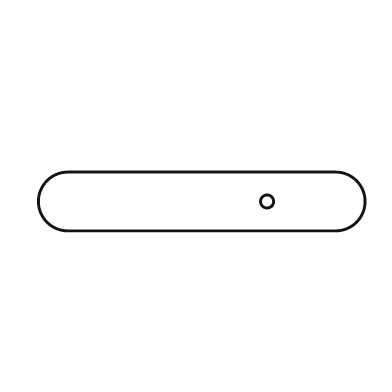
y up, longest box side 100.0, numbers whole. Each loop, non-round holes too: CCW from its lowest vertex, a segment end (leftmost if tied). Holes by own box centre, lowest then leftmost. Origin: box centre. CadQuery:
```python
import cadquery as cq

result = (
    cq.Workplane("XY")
    .moveTo(-41.0, -9.0)
    .lineTo(41.0, -9.0)
    .threePointArc((50.0, 0.0), (41.0, 9.0))
    .lineTo(-41.0, 9.0)
    .threePointArc((-50.0, 0.0), (-41.0, -9.0))
    .close()
    .moveTo(20.0, 0.0)
    .circle(2.0)
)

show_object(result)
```